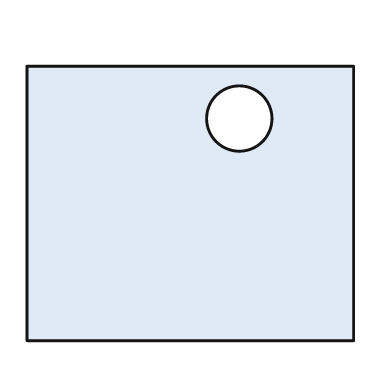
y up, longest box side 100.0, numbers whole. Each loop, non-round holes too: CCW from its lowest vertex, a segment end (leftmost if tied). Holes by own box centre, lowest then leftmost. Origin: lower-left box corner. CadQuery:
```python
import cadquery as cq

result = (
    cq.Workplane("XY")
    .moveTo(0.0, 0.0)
    .lineTo(100.0, 0.0)
    .lineTo(100.0, 84.0)
    .lineTo(0.0, 84.0)
    .close()
    .moveTo(65.0, 68.0)
    .circle(10.0)
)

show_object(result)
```